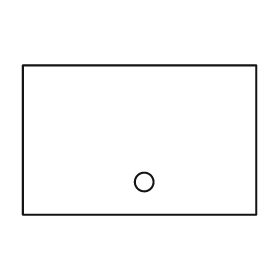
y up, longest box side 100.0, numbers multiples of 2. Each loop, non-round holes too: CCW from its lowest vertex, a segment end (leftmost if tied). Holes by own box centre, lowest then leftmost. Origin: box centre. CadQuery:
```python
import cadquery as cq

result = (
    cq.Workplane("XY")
    .moveTo(-50.0, -32.0)
    .lineTo(50.0, -32.0)
    .lineTo(50.0, 32.0)
    .lineTo(-50.0, 32.0)
    .close()
    .moveTo(2.0, -18.0)
    .circle(4.0)
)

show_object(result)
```